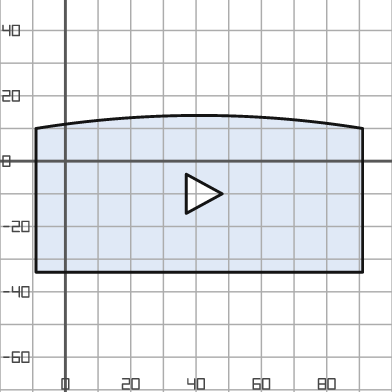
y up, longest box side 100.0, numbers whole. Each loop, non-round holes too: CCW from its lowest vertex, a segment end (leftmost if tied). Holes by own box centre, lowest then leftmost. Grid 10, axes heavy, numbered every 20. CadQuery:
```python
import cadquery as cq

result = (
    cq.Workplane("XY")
    .moveTo(-9.0, -34.0)
    .lineTo(91.0, -34.0)
    .lineTo(91.0, 10.0)
    .threePointArc((41.0, 14.0), (-9.0, 10.0))
    .close()
    .moveTo(37.0, -16.0)
    .lineTo(48.0, -10.0)
    .lineTo(37.0, -4.0)
    .close()
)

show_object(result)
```